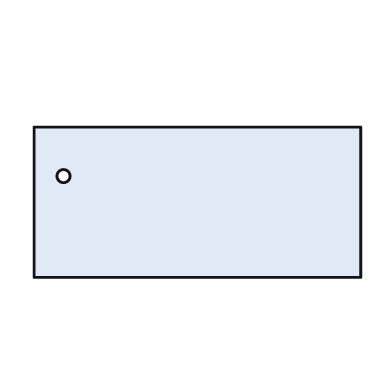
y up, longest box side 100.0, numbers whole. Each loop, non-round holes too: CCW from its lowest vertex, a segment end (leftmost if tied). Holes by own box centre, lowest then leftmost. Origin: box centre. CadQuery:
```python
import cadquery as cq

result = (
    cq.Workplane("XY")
    .moveTo(-50.0, -23.0)
    .lineTo(50.0, -23.0)
    .lineTo(50.0, 23.0)
    .lineTo(-50.0, 23.0)
    .close()
    .moveTo(-41.0, 8.0)
    .circle(2.0)
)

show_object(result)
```